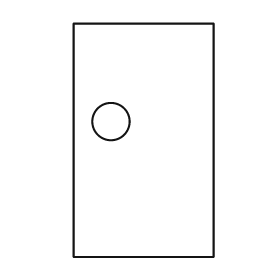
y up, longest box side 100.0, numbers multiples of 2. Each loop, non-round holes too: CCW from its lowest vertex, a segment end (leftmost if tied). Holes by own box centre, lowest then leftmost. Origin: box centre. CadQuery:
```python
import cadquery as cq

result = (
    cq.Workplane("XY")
    .moveTo(-30.0, -50.0)
    .lineTo(30.0, -50.0)
    .lineTo(30.0, 50.0)
    .lineTo(-30.0, 50.0)
    .close()
    .moveTo(-14.0, 8.0)
    .circle(8.0)
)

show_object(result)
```